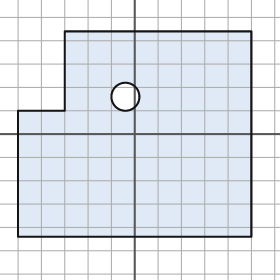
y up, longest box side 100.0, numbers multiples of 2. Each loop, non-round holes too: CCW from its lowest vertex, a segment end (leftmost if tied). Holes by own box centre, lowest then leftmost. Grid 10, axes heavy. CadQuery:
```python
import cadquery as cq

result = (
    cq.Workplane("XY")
    .moveTo(-50.0, -44.0)
    .lineTo(50.0, -44.0)
    .lineTo(50.0, 44.0)
    .lineTo(-30.0, 44.0)
    .lineTo(-30.0, 10.0)
    .lineTo(-50.0, 10.0)
    .close()
    .moveTo(-4.0, 16.0)
    .circle(6.0)
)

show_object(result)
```